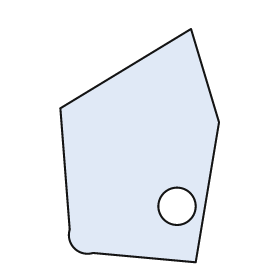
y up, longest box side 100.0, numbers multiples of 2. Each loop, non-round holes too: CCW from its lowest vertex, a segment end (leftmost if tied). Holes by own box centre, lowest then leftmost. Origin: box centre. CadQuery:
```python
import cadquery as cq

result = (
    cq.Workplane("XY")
    .moveTo(24.0, -50.0)
    .lineTo(34.0, 10.0)
    .lineTo(22.0, 50.0)
    .lineTo(-34.0, 16.0)
    .lineTo(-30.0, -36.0)
    .threePointArc((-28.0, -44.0), (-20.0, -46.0))
    .close()
    .moveTo(16.0, -26.0)
    .circle(8.0)
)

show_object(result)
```